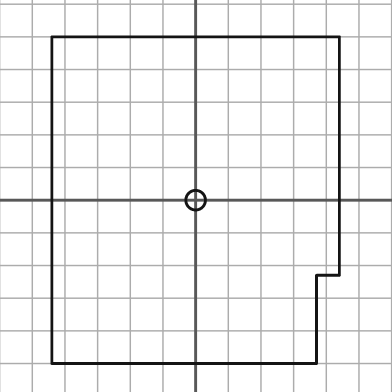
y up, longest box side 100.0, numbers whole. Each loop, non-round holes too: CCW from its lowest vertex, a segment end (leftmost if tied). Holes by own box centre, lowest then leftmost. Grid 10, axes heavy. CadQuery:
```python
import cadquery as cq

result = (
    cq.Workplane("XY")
    .moveTo(-44.0, -50.0)
    .lineTo(37.0, -50.0)
    .lineTo(37.0, -23.0)
    .lineTo(44.0, -23.0)
    .lineTo(44.0, 50.0)
    .lineTo(-44.0, 50.0)
    .close()
    .moveTo(0.0, 0.0)
    .circle(3.0)
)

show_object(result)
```